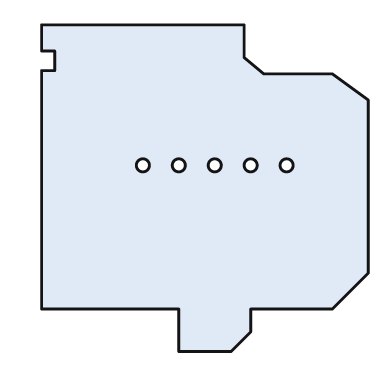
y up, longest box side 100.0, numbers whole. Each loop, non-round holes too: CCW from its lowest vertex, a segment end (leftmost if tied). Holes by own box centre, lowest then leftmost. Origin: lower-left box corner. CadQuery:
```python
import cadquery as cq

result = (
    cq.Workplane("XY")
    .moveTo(42.0, 0.0)
    .lineTo(58.0, 0.0)
    .lineTo(64.0, 6.0)
    .lineTo(64.0, 13.0)
    .lineTo(89.0, 13.0)
    .lineTo(100.0, 24.0)
    .lineTo(100.0, 77.0)
    .lineTo(89.0, 85.0)
    .lineTo(68.0, 85.0)
    .lineTo(62.0, 90.0)
    .lineTo(62.0, 100.0)
    .lineTo(0.0, 100.0)
    .lineTo(0.0, 92.0)
    .lineTo(4.0, 92.0)
    .lineTo(4.0, 86.0)
    .lineTo(0.0, 86.0)
    .lineTo(0.0, 13.0)
    .lineTo(42.0, 13.0)
    .close()
    .moveTo(31.0, 57.0)
    .circle(2.0)
    .moveTo(42.0, 57.0)
    .circle(2.0)
    .moveTo(53.0, 57.0)
    .circle(2.0)
    .moveTo(64.0, 57.0)
    .circle(2.0)
    .moveTo(75.0, 57.0)
    .circle(2.0)
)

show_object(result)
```